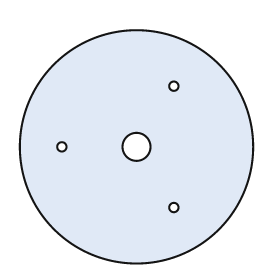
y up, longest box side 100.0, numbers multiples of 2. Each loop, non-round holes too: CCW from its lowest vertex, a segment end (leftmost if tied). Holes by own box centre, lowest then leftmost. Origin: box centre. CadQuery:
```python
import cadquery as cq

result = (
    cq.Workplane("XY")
    .moveTo(0.0, 0.0)
    .circle(50.0)
    .moveTo(16.0, -26.0)
    .circle(2.0)
    .moveTo(-32.0, 0.0)
    .circle(2.0)
    .moveTo(0.0, 0.0)
    .circle(6.0)
    .moveTo(16.0, 26.0)
    .circle(2.0)
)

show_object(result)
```